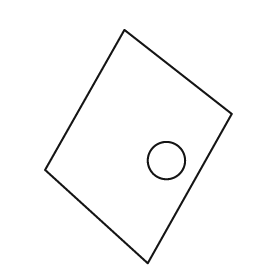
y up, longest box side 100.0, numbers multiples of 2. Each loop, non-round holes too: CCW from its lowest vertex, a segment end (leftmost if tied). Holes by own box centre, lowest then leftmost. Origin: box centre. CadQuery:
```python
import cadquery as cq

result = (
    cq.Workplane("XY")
    .moveTo(4.0, -50.0)
    .lineTo(40.0, 14.0)
    .lineTo(-6.0, 50.0)
    .lineTo(-40.0, -10.0)
    .close()
    .moveTo(12.0, -6.0)
    .circle(8.0)
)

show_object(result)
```